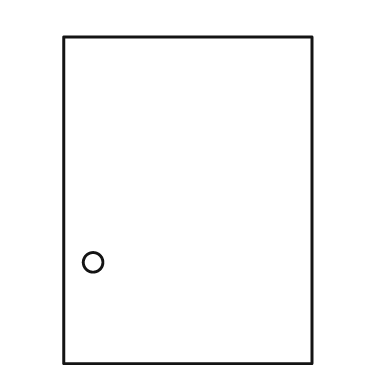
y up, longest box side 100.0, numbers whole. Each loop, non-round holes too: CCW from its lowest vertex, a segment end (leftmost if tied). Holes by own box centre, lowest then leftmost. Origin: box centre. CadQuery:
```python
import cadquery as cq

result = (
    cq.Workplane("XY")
    .moveTo(-38.0, -50.0)
    .lineTo(38.0, -50.0)
    .lineTo(38.0, 50.0)
    .lineTo(-38.0, 50.0)
    .close()
    .moveTo(-29.0, -19.0)
    .circle(3.0)
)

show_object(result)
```